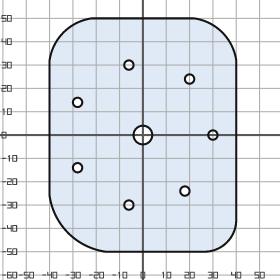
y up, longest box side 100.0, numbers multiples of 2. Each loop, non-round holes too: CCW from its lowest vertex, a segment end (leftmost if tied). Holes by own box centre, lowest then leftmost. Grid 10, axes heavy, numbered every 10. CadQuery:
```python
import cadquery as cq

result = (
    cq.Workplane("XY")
    .moveTo(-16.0, -50.0)
    .lineTo(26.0, -50.0)
    .threePointArc((36.0, -46.0), (40.0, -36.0))
    .lineTo(40.0, 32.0)
    .threePointArc((34.0, 44.0), (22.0, 50.0))
    .lineTo(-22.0, 50.0)
    .threePointArc((-34.0, 44.0), (-40.0, 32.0))
    .lineTo(-40.0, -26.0)
    .threePointArc((-32.0, -42.0), (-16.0, -50.0))
    .close()
    .moveTo(-6.0, -30.0)
    .circle(2.0)
    .moveTo(18.0, -24.0)
    .circle(2.0)
    .moveTo(-28.0, -14.0)
    .circle(2.0)
    .moveTo(0.0, 0.0)
    .circle(4.0)
    .moveTo(30.0, 0.0)
    .circle(2.0)
    .moveTo(-28.0, 14.0)
    .circle(2.0)
    .moveTo(20.0, 24.0)
    .circle(2.0)
    .moveTo(-6.0, 30.0)
    .circle(2.0)
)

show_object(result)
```